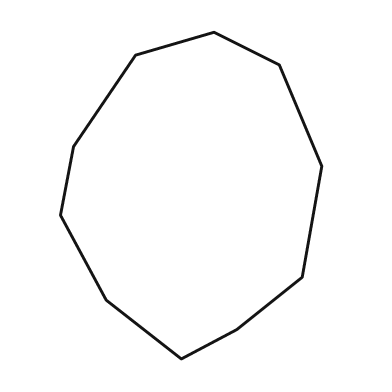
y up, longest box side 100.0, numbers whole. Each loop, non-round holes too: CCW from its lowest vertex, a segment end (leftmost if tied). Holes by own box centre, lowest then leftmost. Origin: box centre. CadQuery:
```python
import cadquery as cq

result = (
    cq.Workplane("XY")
    .moveTo(-3.0, -50.0)
    .lineTo(14.0, -41.0)
    .lineTo(34.0, -25.0)
    .lineTo(40.0, 9.0)
    .lineTo(27.0, 40.0)
    .lineTo(7.0, 50.0)
    .lineTo(-17.0, 43.0)
    .lineTo(-36.0, 15.0)
    .lineTo(-40.0, -6.0)
    .lineTo(-26.0, -32.0)
    .close()
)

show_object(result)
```